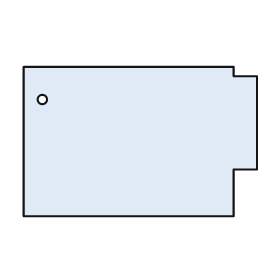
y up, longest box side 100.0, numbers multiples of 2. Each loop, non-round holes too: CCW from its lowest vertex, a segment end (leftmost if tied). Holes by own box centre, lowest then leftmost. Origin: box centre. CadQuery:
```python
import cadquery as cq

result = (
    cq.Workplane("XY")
    .moveTo(-50.0, -32.0)
    .lineTo(40.0, -32.0)
    .lineTo(40.0, -12.0)
    .lineTo(50.0, -12.0)
    .lineTo(50.0, 28.0)
    .lineTo(40.0, 28.0)
    .lineTo(40.0, 32.0)
    .lineTo(-50.0, 32.0)
    .close()
    .moveTo(-42.0, 18.0)
    .circle(2.0)
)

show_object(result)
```